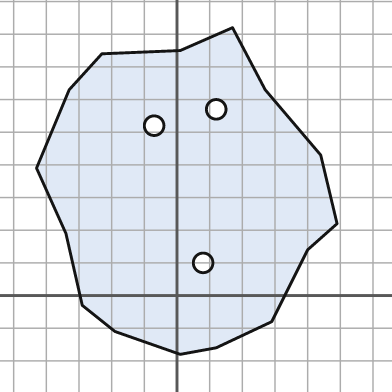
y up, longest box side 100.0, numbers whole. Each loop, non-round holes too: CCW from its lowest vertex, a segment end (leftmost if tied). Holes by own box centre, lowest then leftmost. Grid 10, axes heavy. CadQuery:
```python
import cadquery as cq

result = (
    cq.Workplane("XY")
    .moveTo(1.0, -18.0)
    .lineTo(12.0, -16.0)
    .lineTo(29.0, -8.0)
    .lineTo(40.0, 14.0)
    .lineTo(49.0, 22.0)
    .lineTo(44.0, 43.0)
    .lineTo(27.0, 63.0)
    .lineTo(17.0, 82.0)
    .lineTo(1.0, 75.0)
    .lineTo(-23.0, 74.0)
    .lineTo(-33.0, 63.0)
    .lineTo(-43.0, 39.0)
    .lineTo(-34.0, 19.0)
    .lineTo(-29.0, -3.0)
    .lineTo(-19.0, -11.0)
    .close()
    .moveTo(8.0, 10.0)
    .circle(3.0)
    .moveTo(-7.0, 52.0)
    .circle(3.0)
    .moveTo(12.0, 57.0)
    .circle(3.0)
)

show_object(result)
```